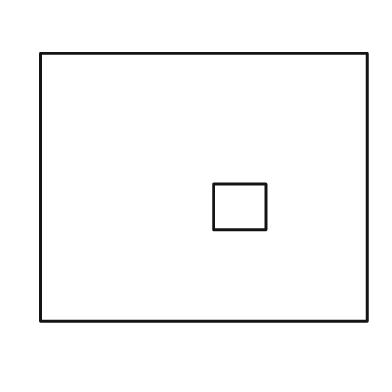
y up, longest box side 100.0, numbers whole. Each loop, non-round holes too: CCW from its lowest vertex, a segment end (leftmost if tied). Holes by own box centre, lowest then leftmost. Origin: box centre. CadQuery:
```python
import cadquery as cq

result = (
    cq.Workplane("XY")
    .moveTo(-50.0, -41.0)
    .lineTo(50.0, -41.0)
    .lineTo(50.0, 41.0)
    .lineTo(-50.0, 41.0)
    .close()
    .moveTo(3.0, -13.0)
    .lineTo(19.0, -13.0)
    .lineTo(19.0, 1.0)
    .lineTo(3.0, 1.0)
    .close()
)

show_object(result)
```